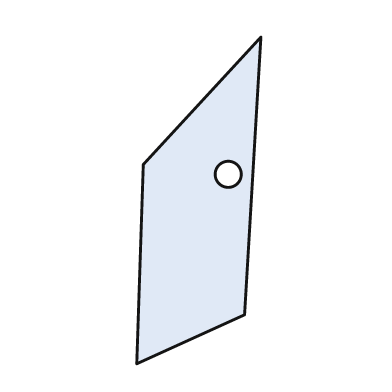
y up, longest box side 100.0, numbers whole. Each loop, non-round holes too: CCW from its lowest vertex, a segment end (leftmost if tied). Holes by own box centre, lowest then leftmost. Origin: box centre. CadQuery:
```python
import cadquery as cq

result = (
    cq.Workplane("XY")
    .moveTo(-19.0, -50.0)
    .lineTo(14.0, -35.0)
    .lineTo(19.0, 50.0)
    .lineTo(-17.0, 11.0)
    .close()
    .moveTo(9.0, 8.0)
    .circle(4.0)
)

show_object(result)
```